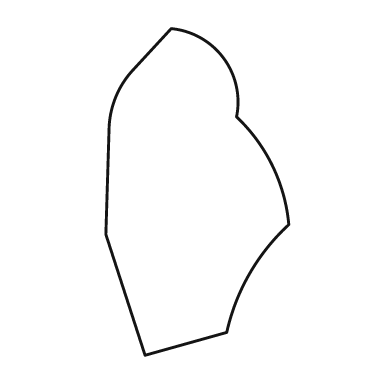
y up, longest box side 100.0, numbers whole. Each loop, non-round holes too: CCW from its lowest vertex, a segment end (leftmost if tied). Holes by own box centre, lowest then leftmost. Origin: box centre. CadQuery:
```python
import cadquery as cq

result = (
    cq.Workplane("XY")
    .moveTo(-16.0, -50.0)
    .lineTo(9.0, -43.0)
    .threePointArc((16.0, -25.0), (28.0, -10.0))
    .threePointArc((23.0, 8.0), (12.0, 23.0))
    .threePointArc((8.0, 41.0), (-8.0, 50.0))
    .lineTo(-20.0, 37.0)
    .threePointArc((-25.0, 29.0), (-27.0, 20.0))
    .lineTo(-28.0, -13.0)
    .close()
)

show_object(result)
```